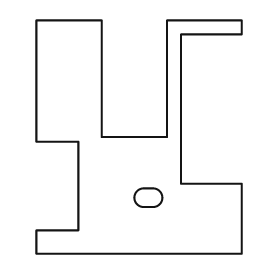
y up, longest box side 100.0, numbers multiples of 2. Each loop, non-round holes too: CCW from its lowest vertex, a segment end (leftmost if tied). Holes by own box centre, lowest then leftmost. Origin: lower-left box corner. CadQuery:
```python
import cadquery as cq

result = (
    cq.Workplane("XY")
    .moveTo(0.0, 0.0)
    .lineTo(88.0, 0.0)
    .lineTo(88.0, 30.0)
    .lineTo(62.0, 30.0)
    .lineTo(62.0, 94.0)
    .lineTo(88.0, 94.0)
    .lineTo(88.0, 100.0)
    .lineTo(56.0, 100.0)
    .lineTo(56.0, 50.0)
    .lineTo(28.0, 50.0)
    .lineTo(28.0, 100.0)
    .lineTo(0.0, 100.0)
    .lineTo(0.0, 48.0)
    .lineTo(18.0, 48.0)
    .lineTo(18.0, 10.0)
    .lineTo(0.0, 10.0)
    .close()
    .moveTo(46.0, 20.0)
    .lineTo(50.0, 20.0)
    .threePointArc((54.0, 24.0), (50.0, 28.0))
    .lineTo(46.0, 28.0)
    .threePointArc((42.0, 24.0), (46.0, 20.0))
    .close()
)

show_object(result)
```